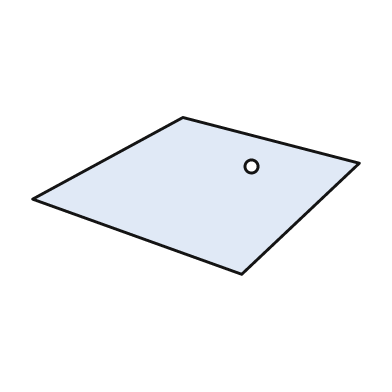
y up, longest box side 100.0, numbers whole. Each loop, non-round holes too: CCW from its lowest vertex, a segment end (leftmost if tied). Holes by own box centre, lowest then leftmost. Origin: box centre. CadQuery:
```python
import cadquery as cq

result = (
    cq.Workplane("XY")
    .moveTo(14.0, -24.0)
    .lineTo(50.0, 10.0)
    .lineTo(-4.0, 24.0)
    .lineTo(-50.0, -1.0)
    .close()
    .moveTo(17.0, 9.0)
    .circle(2.0)
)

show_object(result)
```